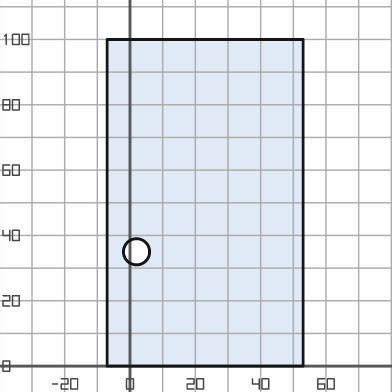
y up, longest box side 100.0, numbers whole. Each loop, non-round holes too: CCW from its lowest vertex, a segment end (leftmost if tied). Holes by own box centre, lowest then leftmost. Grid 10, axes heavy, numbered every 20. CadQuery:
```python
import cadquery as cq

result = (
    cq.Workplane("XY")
    .moveTo(-7.0, 0.0)
    .lineTo(53.0, 0.0)
    .lineTo(53.0, 100.0)
    .lineTo(-7.0, 100.0)
    .close()
    .moveTo(2.0, 35.0)
    .circle(4.0)
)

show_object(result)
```